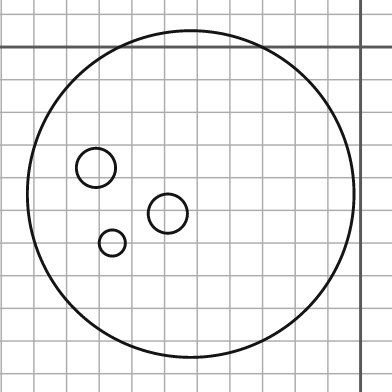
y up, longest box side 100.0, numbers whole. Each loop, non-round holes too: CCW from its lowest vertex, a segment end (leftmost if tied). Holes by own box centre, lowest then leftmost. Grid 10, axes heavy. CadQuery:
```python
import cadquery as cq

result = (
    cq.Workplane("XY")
    .moveTo(-52.0, -45.0)
    .circle(50.0)
    .moveTo(-76.0, -60.0)
    .circle(4.0)
    .moveTo(-59.0, -51.0)
    .circle(6.0)
    .moveTo(-81.0, -37.0)
    .circle(6.0)
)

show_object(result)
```